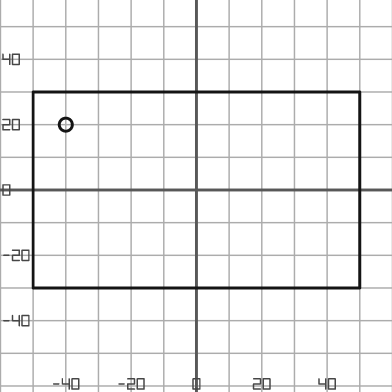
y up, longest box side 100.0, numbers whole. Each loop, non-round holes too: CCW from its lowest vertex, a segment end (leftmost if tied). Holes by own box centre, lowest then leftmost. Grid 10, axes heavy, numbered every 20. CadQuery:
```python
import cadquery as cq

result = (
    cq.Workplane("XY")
    .moveTo(-50.0, -30.0)
    .lineTo(50.0, -30.0)
    .lineTo(50.0, 30.0)
    .lineTo(-50.0, 30.0)
    .close()
    .moveTo(-40.0, 20.0)
    .circle(2.0)
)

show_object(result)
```